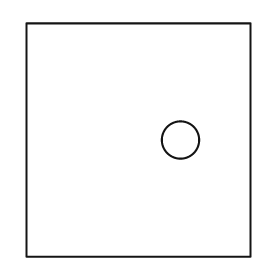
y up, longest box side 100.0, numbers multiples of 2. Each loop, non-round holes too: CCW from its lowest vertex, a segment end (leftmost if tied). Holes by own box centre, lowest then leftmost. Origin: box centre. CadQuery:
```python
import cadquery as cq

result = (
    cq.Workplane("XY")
    .moveTo(-48.0, -50.0)
    .lineTo(48.0, -50.0)
    .lineTo(48.0, 50.0)
    .lineTo(-48.0, 50.0)
    .close()
    .moveTo(18.0, 0.0)
    .circle(8.0)
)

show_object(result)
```